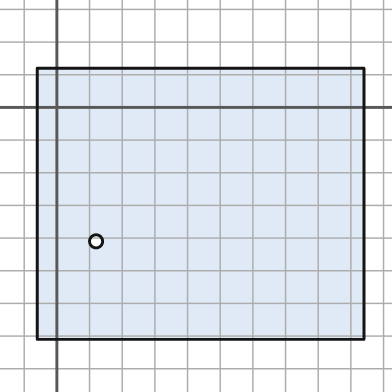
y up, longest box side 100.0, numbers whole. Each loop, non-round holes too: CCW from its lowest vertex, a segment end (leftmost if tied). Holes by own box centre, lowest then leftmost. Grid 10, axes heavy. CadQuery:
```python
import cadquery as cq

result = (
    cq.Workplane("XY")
    .moveTo(-6.0, -71.0)
    .lineTo(94.0, -71.0)
    .lineTo(94.0, 12.0)
    .lineTo(-6.0, 12.0)
    .close()
    .moveTo(12.0, -41.0)
    .circle(2.0)
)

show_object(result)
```